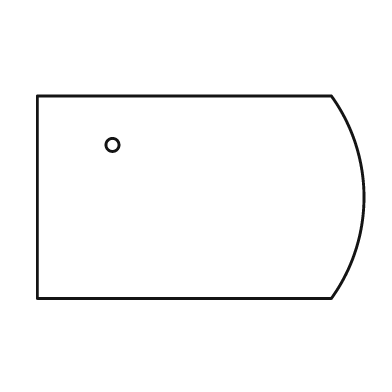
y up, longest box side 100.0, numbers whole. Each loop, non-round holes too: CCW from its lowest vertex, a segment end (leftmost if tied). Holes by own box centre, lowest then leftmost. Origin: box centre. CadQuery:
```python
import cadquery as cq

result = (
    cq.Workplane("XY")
    .moveTo(-50.0, -31.0)
    .lineTo(40.0, -31.0)
    .threePointArc((50.0, 0.0), (40.0, 31.0))
    .lineTo(-50.0, 31.0)
    .close()
    .moveTo(-27.0, 16.0)
    .circle(2.0)
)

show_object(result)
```